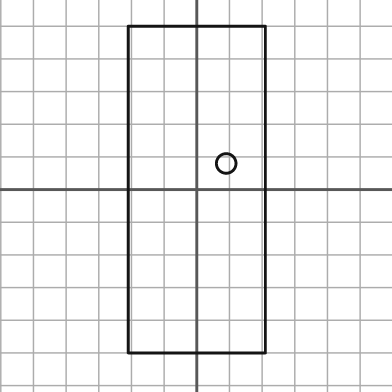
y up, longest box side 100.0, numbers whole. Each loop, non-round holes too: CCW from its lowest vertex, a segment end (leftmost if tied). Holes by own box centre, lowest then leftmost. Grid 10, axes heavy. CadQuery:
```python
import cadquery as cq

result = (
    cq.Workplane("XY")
    .moveTo(-21.0, -50.0)
    .lineTo(21.0, -50.0)
    .lineTo(21.0, 50.0)
    .lineTo(-21.0, 50.0)
    .close()
    .moveTo(9.0, 8.0)
    .circle(3.0)
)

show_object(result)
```